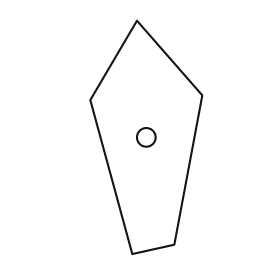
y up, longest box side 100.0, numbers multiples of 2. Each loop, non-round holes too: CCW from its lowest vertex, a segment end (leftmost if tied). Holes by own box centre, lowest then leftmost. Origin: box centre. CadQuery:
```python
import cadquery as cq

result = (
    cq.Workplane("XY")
    .moveTo(-6.0, -50.0)
    .lineTo(12.0, -46.0)
    .lineTo(24.0, 18.0)
    .lineTo(-4.0, 50.0)
    .lineTo(-24.0, 16.0)
    .close()
    .moveTo(0.0, 0.0)
    .circle(4.0)
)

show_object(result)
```